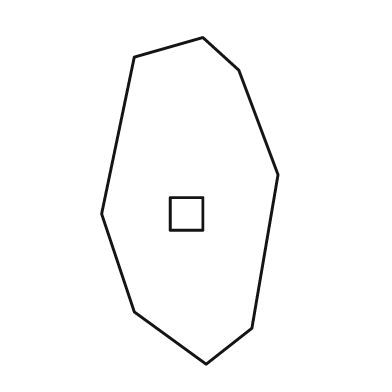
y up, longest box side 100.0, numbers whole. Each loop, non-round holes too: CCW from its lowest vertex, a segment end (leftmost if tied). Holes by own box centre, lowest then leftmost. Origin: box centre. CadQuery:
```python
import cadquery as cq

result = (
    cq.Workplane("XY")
    .moveTo(5.0, -50.0)
    .lineTo(19.0, -39.0)
    .lineTo(27.0, 8.0)
    .lineTo(15.0, 40.0)
    .lineTo(4.0, 50.0)
    .lineTo(-17.0, 44.0)
    .lineTo(-27.0, -4.0)
    .lineTo(-17.0, -34.0)
    .close()
    .moveTo(-6.0, -9.0)
    .lineTo(4.0, -9.0)
    .lineTo(4.0, 1.0)
    .lineTo(-6.0, 1.0)
    .close()
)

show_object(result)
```